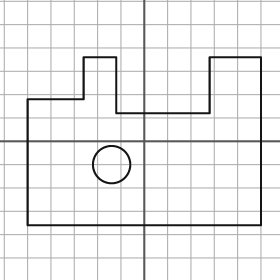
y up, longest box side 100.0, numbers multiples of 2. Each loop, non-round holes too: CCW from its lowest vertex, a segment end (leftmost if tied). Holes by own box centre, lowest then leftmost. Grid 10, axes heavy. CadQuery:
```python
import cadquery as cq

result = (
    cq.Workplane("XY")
    .moveTo(-50.0, -36.0)
    .lineTo(50.0, -36.0)
    .lineTo(50.0, 36.0)
    .lineTo(28.0, 36.0)
    .lineTo(28.0, 12.0)
    .lineTo(-12.0, 12.0)
    .lineTo(-12.0, 36.0)
    .lineTo(-26.0, 36.0)
    .lineTo(-26.0, 18.0)
    .lineTo(-50.0, 18.0)
    .close()
    .moveTo(-14.0, -10.0)
    .circle(8.0)
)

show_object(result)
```